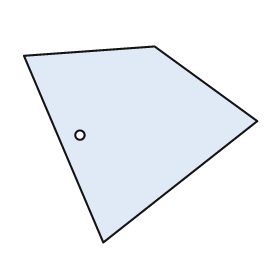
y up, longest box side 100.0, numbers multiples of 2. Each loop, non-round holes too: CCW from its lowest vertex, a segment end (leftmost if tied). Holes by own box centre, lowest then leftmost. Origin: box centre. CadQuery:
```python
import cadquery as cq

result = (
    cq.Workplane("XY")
    .moveTo(-16.0, -42.0)
    .lineTo(50.0, 10.0)
    .lineTo(6.0, 42.0)
    .lineTo(-50.0, 38.0)
    .close()
    .moveTo(-26.0, 4.0)
    .circle(2.0)
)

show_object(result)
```